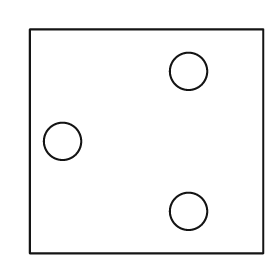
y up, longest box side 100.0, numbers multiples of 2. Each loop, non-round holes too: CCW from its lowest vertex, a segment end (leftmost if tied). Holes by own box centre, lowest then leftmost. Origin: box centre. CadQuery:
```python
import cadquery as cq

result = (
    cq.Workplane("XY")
    .moveTo(-50.0, -48.0)
    .lineTo(50.0, -48.0)
    .lineTo(50.0, 48.0)
    .lineTo(-50.0, 48.0)
    .close()
    .moveTo(18.0, -30.0)
    .circle(8.0)
    .moveTo(-36.0, 0.0)
    .circle(8.0)
    .moveTo(18.0, 30.0)
    .circle(8.0)
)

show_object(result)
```